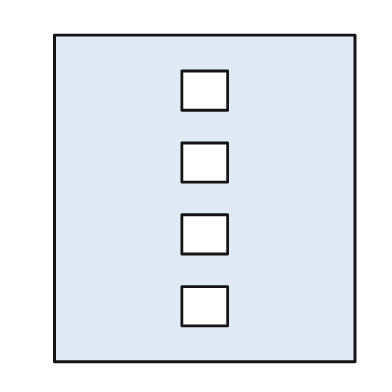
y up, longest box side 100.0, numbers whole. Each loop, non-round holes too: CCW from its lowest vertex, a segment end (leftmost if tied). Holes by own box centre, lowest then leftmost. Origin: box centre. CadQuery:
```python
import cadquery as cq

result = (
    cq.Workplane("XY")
    .moveTo(-46.0, -50.0)
    .lineTo(46.0, -50.0)
    .lineTo(46.0, 50.0)
    .lineTo(-46.0, 50.0)
    .close()
    .moveTo(-7.0, -39.0)
    .lineTo(7.0, -39.0)
    .lineTo(7.0, -27.0)
    .lineTo(-7.0, -27.0)
    .close()
    .moveTo(-7.0, -17.0)
    .lineTo(7.0, -17.0)
    .lineTo(7.0, -5.0)
    .lineTo(-7.0, -5.0)
    .close()
    .moveTo(-7.0, 5.0)
    .lineTo(7.0, 5.0)
    .lineTo(7.0, 17.0)
    .lineTo(-7.0, 17.0)
    .close()
    .moveTo(-7.0, 27.0)
    .lineTo(7.0, 27.0)
    .lineTo(7.0, 39.0)
    .lineTo(-7.0, 39.0)
    .close()
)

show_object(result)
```